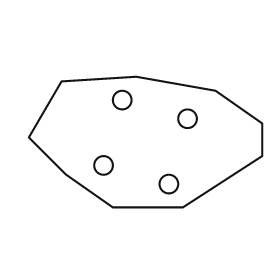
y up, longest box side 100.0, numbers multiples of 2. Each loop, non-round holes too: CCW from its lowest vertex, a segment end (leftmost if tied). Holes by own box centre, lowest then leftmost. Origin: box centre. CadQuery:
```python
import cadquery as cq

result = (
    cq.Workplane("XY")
    .moveTo(-14.0, -28.0)
    .lineTo(16.0, -28.0)
    .lineTo(50.0, -6.0)
    .lineTo(50.0, 8.0)
    .lineTo(30.0, 22.0)
    .lineTo(-4.0, 28.0)
    .lineTo(-36.0, 26.0)
    .lineTo(-50.0, 2.0)
    .lineTo(-34.0, -14.0)
    .close()
    .moveTo(10.0, -18.0)
    .circle(4.0)
    .moveTo(-18.0, -10.0)
    .circle(4.0)
    .moveTo(18.0, 10.0)
    .circle(4.0)
    .moveTo(-10.0, 18.0)
    .circle(4.0)
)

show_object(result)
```